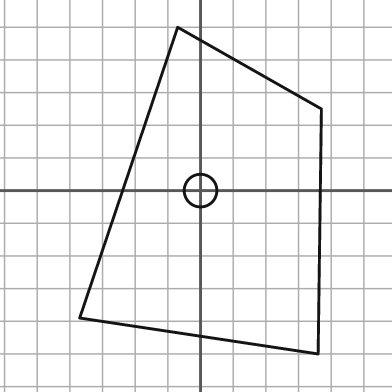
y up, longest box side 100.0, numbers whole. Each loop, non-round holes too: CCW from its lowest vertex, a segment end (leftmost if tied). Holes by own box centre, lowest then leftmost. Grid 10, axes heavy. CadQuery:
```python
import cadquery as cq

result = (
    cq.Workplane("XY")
    .moveTo(36.0, -50.0)
    .lineTo(37.0, 25.0)
    .lineTo(-7.0, 50.0)
    .lineTo(-37.0, -39.0)
    .close()
    .moveTo(0.0, 0.0)
    .circle(5.0)
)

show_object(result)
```